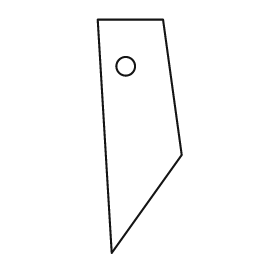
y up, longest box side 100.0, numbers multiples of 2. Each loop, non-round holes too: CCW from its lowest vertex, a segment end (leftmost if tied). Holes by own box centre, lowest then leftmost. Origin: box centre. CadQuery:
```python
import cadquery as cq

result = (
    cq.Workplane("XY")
    .moveTo(-12.0, -50.0)
    .lineTo(18.0, -8.0)
    .lineTo(10.0, 50.0)
    .lineTo(-18.0, 50.0)
    .close()
    .moveTo(-6.0, 30.0)
    .circle(4.0)
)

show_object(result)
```